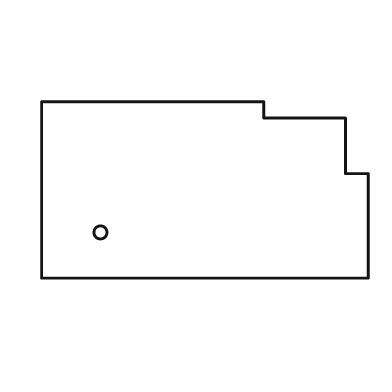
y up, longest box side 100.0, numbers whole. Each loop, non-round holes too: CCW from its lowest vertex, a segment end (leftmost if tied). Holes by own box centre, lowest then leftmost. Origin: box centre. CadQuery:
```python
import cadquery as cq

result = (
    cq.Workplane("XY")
    .moveTo(-50.0, -27.0)
    .lineTo(50.0, -27.0)
    .lineTo(50.0, 5.0)
    .lineTo(43.0, 5.0)
    .lineTo(43.0, 22.0)
    .lineTo(18.0, 22.0)
    .lineTo(18.0, 27.0)
    .lineTo(-50.0, 27.0)
    .close()
    .moveTo(-32.0, -13.0)
    .circle(2.0)
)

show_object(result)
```